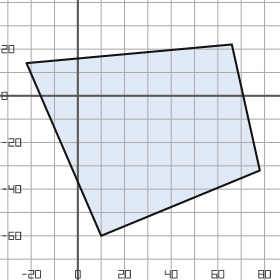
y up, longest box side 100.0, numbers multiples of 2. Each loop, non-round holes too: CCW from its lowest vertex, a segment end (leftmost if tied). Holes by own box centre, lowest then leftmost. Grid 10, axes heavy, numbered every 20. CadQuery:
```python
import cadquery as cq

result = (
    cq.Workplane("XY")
    .moveTo(10.0, -60.0)
    .lineTo(78.0, -32.0)
    .lineTo(66.0, 22.0)
    .lineTo(-22.0, 14.0)
    .close()
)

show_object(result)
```